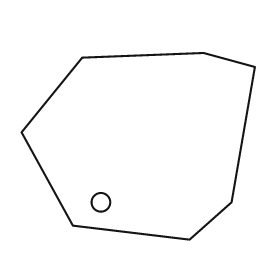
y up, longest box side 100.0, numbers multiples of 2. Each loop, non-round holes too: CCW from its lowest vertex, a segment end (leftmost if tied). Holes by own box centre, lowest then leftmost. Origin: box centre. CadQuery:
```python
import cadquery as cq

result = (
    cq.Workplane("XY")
    .moveTo(22.0, -40.0)
    .lineTo(40.0, -24.0)
    .lineTo(50.0, 34.0)
    .lineTo(28.0, 40.0)
    .lineTo(-24.0, 38.0)
    .lineTo(-50.0, 6.0)
    .lineTo(-28.0, -34.0)
    .close()
    .moveTo(-16.0, -24.0)
    .circle(4.0)
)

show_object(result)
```